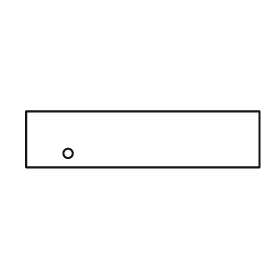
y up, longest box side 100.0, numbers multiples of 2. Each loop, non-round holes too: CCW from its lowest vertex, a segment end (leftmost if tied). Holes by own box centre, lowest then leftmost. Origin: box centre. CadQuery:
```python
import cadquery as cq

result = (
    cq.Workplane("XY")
    .moveTo(-50.0, -12.0)
    .lineTo(50.0, -12.0)
    .lineTo(50.0, 12.0)
    .lineTo(-50.0, 12.0)
    .close()
    .moveTo(-32.0, -6.0)
    .circle(2.0)
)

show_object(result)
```